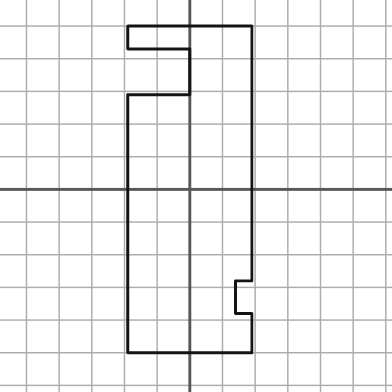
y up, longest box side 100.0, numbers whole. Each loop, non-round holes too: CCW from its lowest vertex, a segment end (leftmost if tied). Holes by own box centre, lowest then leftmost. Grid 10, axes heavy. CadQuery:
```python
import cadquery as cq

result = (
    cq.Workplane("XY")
    .moveTo(-19.0, -50.0)
    .lineTo(19.0, -50.0)
    .lineTo(19.0, -38.0)
    .lineTo(14.0, -38.0)
    .lineTo(14.0, -28.0)
    .lineTo(19.0, -28.0)
    .lineTo(19.0, 50.0)
    .lineTo(-19.0, 50.0)
    .lineTo(-19.0, 43.0)
    .lineTo(0.0, 43.0)
    .lineTo(0.0, 29.0)
    .lineTo(-19.0, 29.0)
    .close()
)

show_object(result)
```